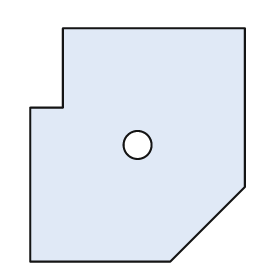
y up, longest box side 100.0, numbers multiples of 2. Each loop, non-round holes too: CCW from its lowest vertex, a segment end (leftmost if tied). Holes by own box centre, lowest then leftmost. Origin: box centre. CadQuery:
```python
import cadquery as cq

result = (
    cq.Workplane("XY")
    .moveTo(-46.0, -50.0)
    .lineTo(14.0, -50.0)
    .lineTo(46.0, -18.0)
    .lineTo(46.0, 50.0)
    .lineTo(-32.0, 50.0)
    .lineTo(-32.0, 16.0)
    .lineTo(-46.0, 16.0)
    .close()
    .moveTo(0.0, 0.0)
    .circle(6.0)
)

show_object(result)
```